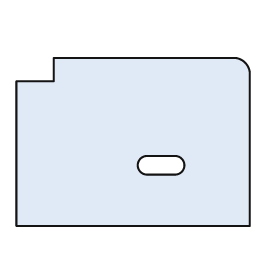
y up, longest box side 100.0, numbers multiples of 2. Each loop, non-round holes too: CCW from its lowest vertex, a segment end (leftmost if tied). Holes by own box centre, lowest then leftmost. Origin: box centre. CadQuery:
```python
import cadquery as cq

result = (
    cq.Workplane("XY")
    .moveTo(-50.0, -36.0)
    .lineTo(50.0, -36.0)
    .lineTo(50.0, 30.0)
    .threePointArc((48.0, 34.0), (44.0, 36.0))
    .lineTo(-34.0, 36.0)
    .lineTo(-34.0, 26.0)
    .lineTo(-50.0, 26.0)
    .close()
    .moveTo(6.0, -14.0)
    .lineTo(18.0, -14.0)
    .threePointArc((22.0, -10.0), (18.0, -6.0))
    .lineTo(6.0, -6.0)
    .threePointArc((2.0, -10.0), (6.0, -14.0))
    .close()
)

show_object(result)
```